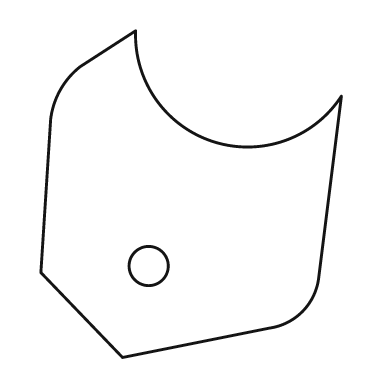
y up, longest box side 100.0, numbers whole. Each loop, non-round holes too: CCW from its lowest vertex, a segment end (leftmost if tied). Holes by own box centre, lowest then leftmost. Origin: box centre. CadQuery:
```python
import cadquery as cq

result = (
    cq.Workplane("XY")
    .moveTo(-21.0, -50.0)
    .lineTo(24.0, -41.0)
    .threePointArc((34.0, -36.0), (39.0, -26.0))
    .lineTo(46.0, 30.0)
    .threePointArc((7.0, 16.0), (-17.0, 50.0))
    .lineTo(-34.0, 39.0)
    .threePointArc((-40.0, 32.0), (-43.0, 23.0))
    .lineTo(-46.0, -24.0)
    .close()
    .moveTo(-13.0, -22.0)
    .circle(6.0)
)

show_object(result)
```